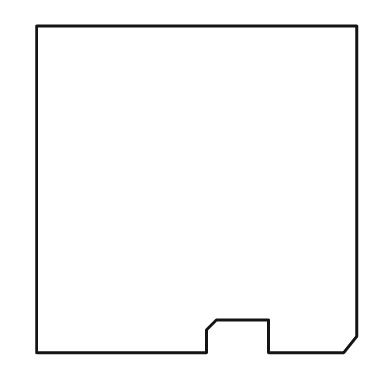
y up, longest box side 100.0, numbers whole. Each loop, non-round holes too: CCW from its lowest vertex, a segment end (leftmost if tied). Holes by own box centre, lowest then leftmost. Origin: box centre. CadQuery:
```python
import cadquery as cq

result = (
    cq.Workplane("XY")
    .moveTo(-49.0, -50.0)
    .lineTo(3.0, -50.0)
    .lineTo(3.0, -43.0)
    .lineTo(6.0, -40.0)
    .lineTo(22.0, -40.0)
    .lineTo(22.0, -50.0)
    .lineTo(45.0, -50.0)
    .lineTo(49.0, -45.0)
    .lineTo(49.0, 50.0)
    .lineTo(-49.0, 50.0)
    .close()
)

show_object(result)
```